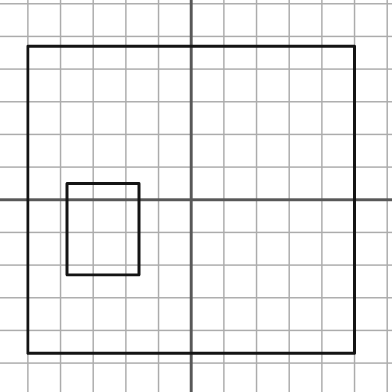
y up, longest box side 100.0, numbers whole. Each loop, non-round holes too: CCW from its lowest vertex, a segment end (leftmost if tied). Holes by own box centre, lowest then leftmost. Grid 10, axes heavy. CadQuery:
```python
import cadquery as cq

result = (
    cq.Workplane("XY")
    .moveTo(-50.0, -47.0)
    .lineTo(50.0, -47.0)
    .lineTo(50.0, 47.0)
    .lineTo(-50.0, 47.0)
    .close()
    .moveTo(-38.0, -23.0)
    .lineTo(-16.0, -23.0)
    .lineTo(-16.0, 5.0)
    .lineTo(-38.0, 5.0)
    .close()
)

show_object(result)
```